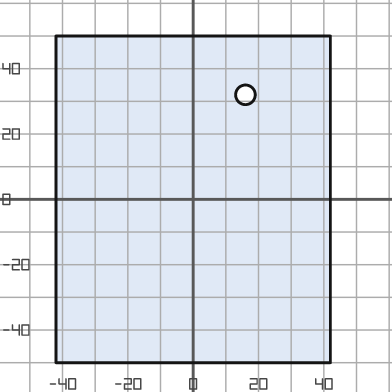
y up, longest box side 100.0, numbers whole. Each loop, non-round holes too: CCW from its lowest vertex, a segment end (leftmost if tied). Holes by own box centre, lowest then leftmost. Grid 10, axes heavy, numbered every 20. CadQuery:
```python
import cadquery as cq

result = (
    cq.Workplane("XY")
    .moveTo(-42.0, -50.0)
    .lineTo(42.0, -50.0)
    .lineTo(42.0, 50.0)
    .lineTo(-42.0, 50.0)
    .close()
    .moveTo(16.0, 32.0)
    .circle(3.0)
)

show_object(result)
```